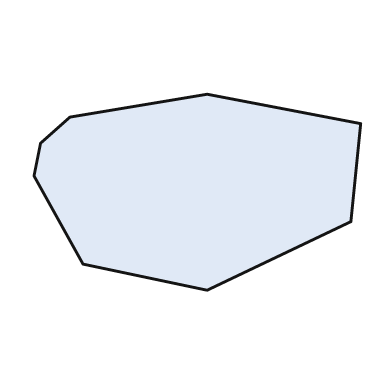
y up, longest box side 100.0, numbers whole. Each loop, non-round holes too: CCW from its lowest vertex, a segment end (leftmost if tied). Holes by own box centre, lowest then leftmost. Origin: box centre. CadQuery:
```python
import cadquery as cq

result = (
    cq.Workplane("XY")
    .moveTo(3.0, -30.0)
    .lineTo(47.0, -9.0)
    .lineTo(50.0, 21.0)
    .lineTo(3.0, 30.0)
    .lineTo(-39.0, 23.0)
    .lineTo(-48.0, 15.0)
    .lineTo(-50.0, 5.0)
    .lineTo(-35.0, -22.0)
    .close()
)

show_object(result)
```